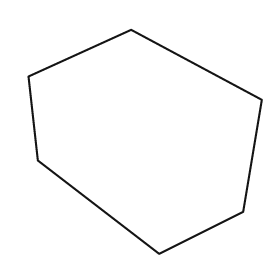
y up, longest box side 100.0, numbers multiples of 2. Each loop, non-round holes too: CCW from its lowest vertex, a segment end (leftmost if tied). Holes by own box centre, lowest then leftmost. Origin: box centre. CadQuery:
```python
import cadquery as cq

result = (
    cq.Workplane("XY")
    .moveTo(6.0, -48.0)
    .lineTo(42.0, -30.0)
    .lineTo(50.0, 18.0)
    .lineTo(-6.0, 48.0)
    .lineTo(-50.0, 28.0)
    .lineTo(-46.0, -8.0)
    .close()
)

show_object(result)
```